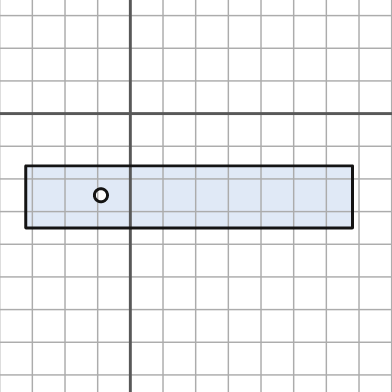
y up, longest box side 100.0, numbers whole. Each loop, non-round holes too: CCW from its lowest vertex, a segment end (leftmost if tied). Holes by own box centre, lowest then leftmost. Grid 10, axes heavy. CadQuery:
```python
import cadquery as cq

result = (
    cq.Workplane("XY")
    .moveTo(-32.0, -35.0)
    .lineTo(68.0, -35.0)
    .lineTo(68.0, -16.0)
    .lineTo(-32.0, -16.0)
    .close()
    .moveTo(-9.0, -25.0)
    .circle(2.0)
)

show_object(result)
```